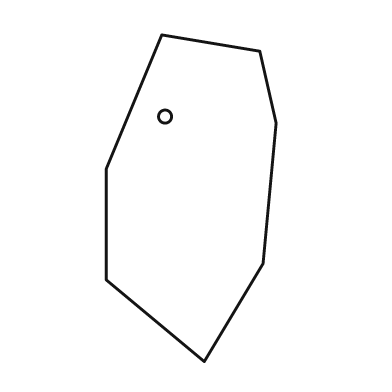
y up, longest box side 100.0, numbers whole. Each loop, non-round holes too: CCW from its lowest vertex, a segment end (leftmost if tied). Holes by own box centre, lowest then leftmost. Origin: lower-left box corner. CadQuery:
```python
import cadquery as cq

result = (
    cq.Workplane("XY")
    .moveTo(30.0, 0.0)
    .lineTo(48.0, 30.0)
    .lineTo(52.0, 73.0)
    .lineTo(47.0, 95.0)
    .lineTo(17.0, 100.0)
    .lineTo(0.0, 59.0)
    .lineTo(0.0, 25.0)
    .close()
    .moveTo(18.0, 75.0)
    .circle(2.0)
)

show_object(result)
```